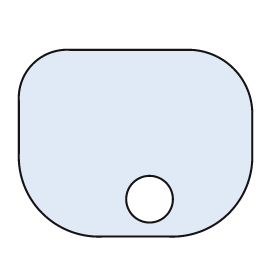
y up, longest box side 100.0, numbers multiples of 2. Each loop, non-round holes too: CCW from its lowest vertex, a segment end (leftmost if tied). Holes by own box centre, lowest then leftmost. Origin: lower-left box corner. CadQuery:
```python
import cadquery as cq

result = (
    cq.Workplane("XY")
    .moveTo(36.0, 0.0)
    .lineTo(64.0, 0.0)
    .threePointArc((90.0, 10.0), (100.0, 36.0))
    .lineTo(100.0, 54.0)
    .threePointArc((92.0, 72.0), (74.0, 80.0))
    .lineTo(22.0, 80.0)
    .threePointArc((6.0, 74.0), (0.0, 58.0))
    .lineTo(0.0, 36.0)
    .threePointArc((10.0, 10.0), (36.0, 0.0))
    .close()
    .moveTo(56.0, 16.0)
    .circle(10.0)
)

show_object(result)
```